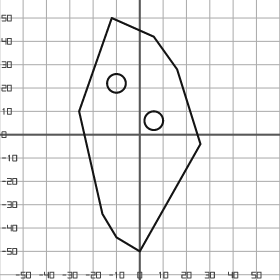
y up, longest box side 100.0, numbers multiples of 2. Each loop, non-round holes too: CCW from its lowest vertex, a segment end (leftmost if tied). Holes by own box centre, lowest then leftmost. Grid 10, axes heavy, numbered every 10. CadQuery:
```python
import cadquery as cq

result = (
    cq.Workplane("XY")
    .moveTo(0.0, -50.0)
    .lineTo(26.0, -4.0)
    .lineTo(16.0, 28.0)
    .lineTo(6.0, 42.0)
    .lineTo(-12.0, 50.0)
    .lineTo(-26.0, 10.0)
    .lineTo(-16.0, -34.0)
    .lineTo(-10.0, -44.0)
    .close()
    .moveTo(6.0, 6.0)
    .circle(4.0)
    .moveTo(-10.0, 22.0)
    .circle(4.0)
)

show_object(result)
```